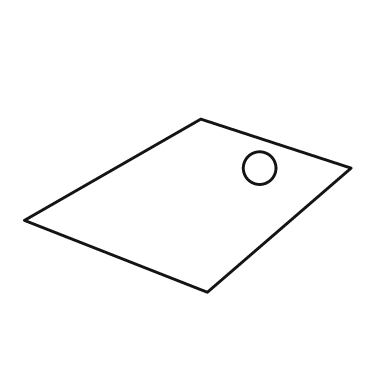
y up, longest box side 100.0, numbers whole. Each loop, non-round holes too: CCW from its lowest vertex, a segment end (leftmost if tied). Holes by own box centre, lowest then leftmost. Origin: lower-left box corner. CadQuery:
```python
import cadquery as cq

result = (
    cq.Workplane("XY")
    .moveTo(56.0, 0.0)
    .lineTo(100.0, 38.0)
    .lineTo(54.0, 53.0)
    .lineTo(0.0, 22.0)
    .close()
    .moveTo(72.0, 38.0)
    .circle(5.0)
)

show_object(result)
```